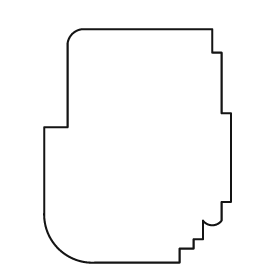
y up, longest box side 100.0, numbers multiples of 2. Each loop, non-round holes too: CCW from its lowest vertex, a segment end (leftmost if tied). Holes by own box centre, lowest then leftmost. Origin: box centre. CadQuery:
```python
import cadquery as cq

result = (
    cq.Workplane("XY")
    .moveTo(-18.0, -50.0)
    .lineTo(18.0, -50.0)
    .lineTo(18.0, -44.0)
    .lineTo(24.0, -44.0)
    .lineTo(24.0, -40.0)
    .lineTo(28.0, -40.0)
    .lineTo(28.0, -32.0)
    .threePointArc((32.0, -34.0), (36.0, -32.0))
    .lineTo(36.0, -24.0)
    .lineTo(40.0, -24.0)
    .lineTo(40.0, 14.0)
    .lineTo(36.0, 14.0)
    .lineTo(36.0, 40.0)
    .lineTo(32.0, 40.0)
    .lineTo(32.0, 50.0)
    .lineTo(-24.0, 50.0)
    .threePointArc((-28.0, 48.0), (-30.0, 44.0))
    .lineTo(-30.0, 8.0)
    .lineTo(-40.0, 8.0)
    .lineTo(-40.0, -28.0)
    .threePointArc((-34.0, -44.0), (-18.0, -50.0))
    .close()
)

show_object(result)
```